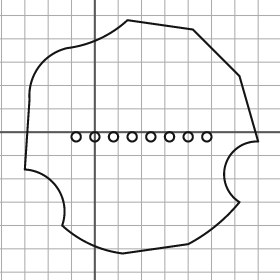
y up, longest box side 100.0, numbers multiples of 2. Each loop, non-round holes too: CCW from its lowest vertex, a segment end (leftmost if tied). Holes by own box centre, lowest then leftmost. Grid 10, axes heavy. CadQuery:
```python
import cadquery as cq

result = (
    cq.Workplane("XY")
    .moveTo(12.0, -52.0)
    .lineTo(40.0, -48.0)
    .threePointArc((52.0, -40.0), (62.0, -30.0))
    .threePointArc((56.0, -14.0), (70.0, -4.0))
    .lineTo(62.0, 24.0)
    .lineTo(42.0, 44.0)
    .lineTo(14.0, 48.0)
    .threePointArc((2.0, 40.0), (-12.0, 36.0))
    .threePointArc((-24.0, 28.0), (-28.0, 14.0))
    .lineTo(-30.0, -16.0)
    .threePointArc((-16.0, -24.0), (-14.0, -40.0))
    .threePointArc((-2.0, -48.0), (12.0, -52.0))
    .close()
    .moveTo(-8.0, -2.0)
    .circle(2.0)
    .moveTo(0.0, -2.0)
    .circle(2.0)
    .moveTo(8.0, -2.0)
    .circle(2.0)
    .moveTo(16.0, -2.0)
    .circle(2.0)
    .moveTo(24.0, -2.0)
    .circle(2.0)
    .moveTo(32.0, -2.0)
    .circle(2.0)
    .moveTo(40.0, -2.0)
    .circle(2.0)
    .moveTo(48.0, -2.0)
    .circle(2.0)
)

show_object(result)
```